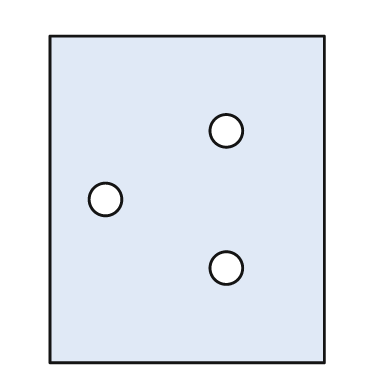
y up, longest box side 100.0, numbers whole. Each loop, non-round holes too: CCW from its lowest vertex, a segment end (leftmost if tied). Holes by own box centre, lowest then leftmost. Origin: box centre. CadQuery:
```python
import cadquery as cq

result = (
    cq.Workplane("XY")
    .moveTo(-42.0, -50.0)
    .lineTo(42.0, -50.0)
    .lineTo(42.0, 50.0)
    .lineTo(-42.0, 50.0)
    .close()
    .moveTo(12.0, -21.0)
    .circle(5.0)
    .moveTo(-25.0, 0.0)
    .circle(5.0)
    .moveTo(12.0, 21.0)
    .circle(5.0)
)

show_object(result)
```